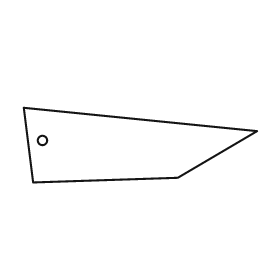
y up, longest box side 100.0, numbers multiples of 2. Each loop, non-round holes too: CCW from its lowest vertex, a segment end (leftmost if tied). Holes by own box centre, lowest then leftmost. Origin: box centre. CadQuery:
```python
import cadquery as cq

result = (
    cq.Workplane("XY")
    .moveTo(-46.0, -16.0)
    .lineTo(16.0, -14.0)
    .lineTo(50.0, 6.0)
    .lineTo(-50.0, 16.0)
    .close()
    .moveTo(-42.0, 2.0)
    .circle(2.0)
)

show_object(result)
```